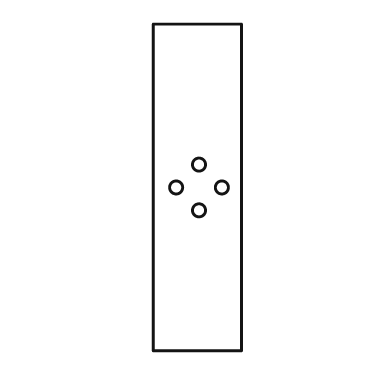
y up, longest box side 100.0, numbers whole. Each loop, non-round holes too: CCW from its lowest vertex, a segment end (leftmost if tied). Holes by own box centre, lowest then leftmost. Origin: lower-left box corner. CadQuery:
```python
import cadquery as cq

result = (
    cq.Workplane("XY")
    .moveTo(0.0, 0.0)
    .lineTo(27.0, 0.0)
    .lineTo(27.0, 100.0)
    .lineTo(0.0, 100.0)
    .close()
    .moveTo(14.0, 43.0)
    .circle(2.0)
    .moveTo(7.0, 50.0)
    .circle(2.0)
    .moveTo(21.0, 50.0)
    .circle(2.0)
    .moveTo(14.0, 57.0)
    .circle(2.0)
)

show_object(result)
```